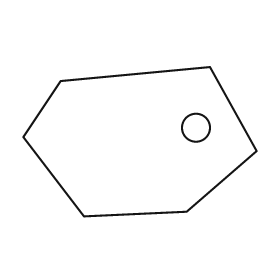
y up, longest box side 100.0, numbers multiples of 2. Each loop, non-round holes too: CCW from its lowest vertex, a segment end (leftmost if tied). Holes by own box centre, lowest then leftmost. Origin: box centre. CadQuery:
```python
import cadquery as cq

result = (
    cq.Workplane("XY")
    .moveTo(-24.0, -32.0)
    .lineTo(20.0, -30.0)
    .lineTo(50.0, -4.0)
    .lineTo(30.0, 32.0)
    .lineTo(-34.0, 26.0)
    .lineTo(-50.0, 2.0)
    .close()
    .moveTo(24.0, 6.0)
    .circle(6.0)
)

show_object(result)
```